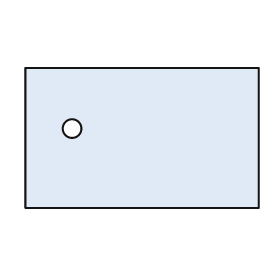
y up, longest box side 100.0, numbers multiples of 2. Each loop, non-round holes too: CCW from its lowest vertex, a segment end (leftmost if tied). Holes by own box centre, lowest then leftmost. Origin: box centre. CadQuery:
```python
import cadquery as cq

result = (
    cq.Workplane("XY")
    .moveTo(-50.0, -30.0)
    .lineTo(50.0, -30.0)
    .lineTo(50.0, 30.0)
    .lineTo(-50.0, 30.0)
    .close()
    .moveTo(-30.0, 4.0)
    .circle(4.0)
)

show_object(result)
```